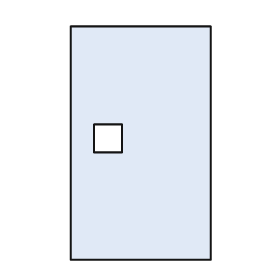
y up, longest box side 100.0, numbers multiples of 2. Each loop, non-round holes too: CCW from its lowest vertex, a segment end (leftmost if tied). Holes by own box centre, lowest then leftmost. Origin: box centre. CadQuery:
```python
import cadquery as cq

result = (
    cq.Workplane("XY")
    .moveTo(-30.0, -50.0)
    .lineTo(30.0, -50.0)
    .lineTo(30.0, 50.0)
    .lineTo(-30.0, 50.0)
    .close()
    .moveTo(-20.0, -4.0)
    .lineTo(-8.0, -4.0)
    .lineTo(-8.0, 8.0)
    .lineTo(-20.0, 8.0)
    .close()
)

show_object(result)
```